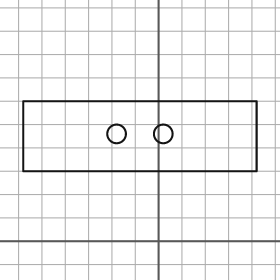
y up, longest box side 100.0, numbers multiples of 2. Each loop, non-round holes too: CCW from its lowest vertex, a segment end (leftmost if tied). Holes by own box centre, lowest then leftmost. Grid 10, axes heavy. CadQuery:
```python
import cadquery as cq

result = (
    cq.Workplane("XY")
    .moveTo(-58.0, 30.0)
    .lineTo(42.0, 30.0)
    .lineTo(42.0, 60.0)
    .lineTo(-58.0, 60.0)
    .close()
    .moveTo(-18.0, 46.0)
    .circle(4.0)
    .moveTo(2.0, 46.0)
    .circle(4.0)
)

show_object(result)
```